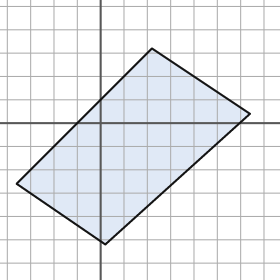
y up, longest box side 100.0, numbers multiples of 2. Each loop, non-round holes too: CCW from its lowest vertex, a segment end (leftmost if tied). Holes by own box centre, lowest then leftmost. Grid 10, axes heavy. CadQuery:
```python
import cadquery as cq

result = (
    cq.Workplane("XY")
    .moveTo(2.0, -52.0)
    .lineTo(64.0, 4.0)
    .lineTo(22.0, 32.0)
    .lineTo(-36.0, -26.0)
    .close()
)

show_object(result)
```